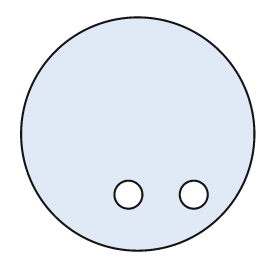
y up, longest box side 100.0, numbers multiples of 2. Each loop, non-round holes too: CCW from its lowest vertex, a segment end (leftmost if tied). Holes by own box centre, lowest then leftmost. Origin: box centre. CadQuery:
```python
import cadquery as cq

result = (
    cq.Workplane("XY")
    .moveTo(0.0, 0.0)
    .circle(50.0)
    .moveTo(-4.0, -26.0)
    .circle(6.0)
    .moveTo(24.0, -26.0)
    .circle(6.0)
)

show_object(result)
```